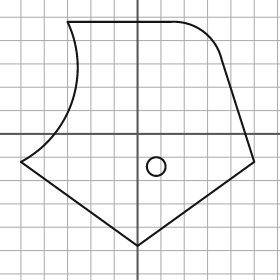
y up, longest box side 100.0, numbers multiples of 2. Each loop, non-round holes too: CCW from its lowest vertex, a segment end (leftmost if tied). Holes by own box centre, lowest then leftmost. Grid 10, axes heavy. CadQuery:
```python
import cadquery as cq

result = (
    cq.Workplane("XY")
    .moveTo(0.0, -48.0)
    .lineTo(50.0, -12.0)
    .lineTo(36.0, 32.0)
    .threePointArc((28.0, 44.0), (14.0, 48.0))
    .lineTo(-30.0, 48.0)
    .threePointArc((-28.0, 14.0), (-50.0, -12.0))
    .close()
    .moveTo(8.0, -14.0)
    .circle(4.0)
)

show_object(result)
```